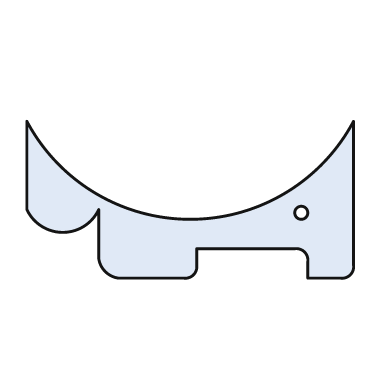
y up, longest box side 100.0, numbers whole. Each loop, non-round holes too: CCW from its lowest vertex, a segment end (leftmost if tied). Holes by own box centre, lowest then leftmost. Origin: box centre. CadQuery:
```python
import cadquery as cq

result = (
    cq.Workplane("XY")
    .moveTo(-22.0, -24.0)
    .lineTo(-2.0, -24.0)
    .threePointArc((1.0, -23.0), (2.0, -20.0))
    .lineTo(2.0, -15.0)
    .lineTo(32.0, -15.0)
    .threePointArc((35.0, -16.0), (36.0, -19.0))
    .lineTo(36.0, -24.0)
    .lineTo(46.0, -24.0)
    .threePointArc((49.0, -23.0), (50.0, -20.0))
    .lineTo(50.0, 24.0)
    .threePointArc((0.0, -6.0), (-50.0, 24.0))
    .lineTo(-50.0, -3.0)
    .threePointArc((-39.0, -10.0), (-28.0, -3.0))
    .lineTo(-28.0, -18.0)
    .threePointArc((-26.0, -22.0), (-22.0, -24.0))
    .close()
    .moveTo(34.0, -4.0)
    .circle(2.0)
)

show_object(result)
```